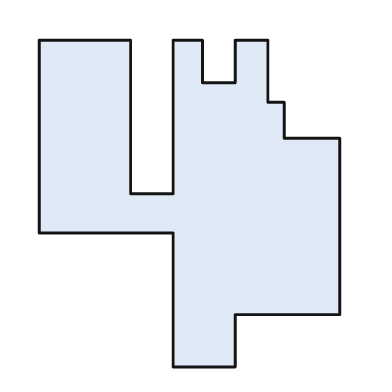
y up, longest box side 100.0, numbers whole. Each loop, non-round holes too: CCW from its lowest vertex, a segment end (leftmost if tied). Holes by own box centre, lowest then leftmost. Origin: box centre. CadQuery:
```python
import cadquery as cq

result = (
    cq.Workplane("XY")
    .moveTo(-5.0, -50.0)
    .lineTo(14.0, -50.0)
    .lineTo(14.0, -34.0)
    .lineTo(46.0, -34.0)
    .lineTo(46.0, 20.0)
    .lineTo(29.0, 20.0)
    .lineTo(29.0, 31.0)
    .lineTo(24.0, 31.0)
    .lineTo(24.0, 50.0)
    .lineTo(14.0, 50.0)
    .lineTo(14.0, 37.0)
    .lineTo(4.0, 37.0)
    .lineTo(4.0, 50.0)
    .lineTo(-5.0, 50.0)
    .lineTo(-5.0, 3.0)
    .lineTo(-18.0, 3.0)
    .lineTo(-18.0, 50.0)
    .lineTo(-46.0, 50.0)
    .lineTo(-46.0, -9.0)
    .lineTo(-5.0, -9.0)
    .close()
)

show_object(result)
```